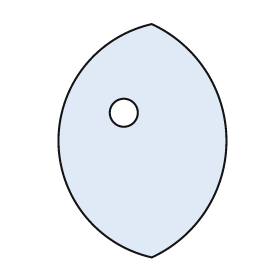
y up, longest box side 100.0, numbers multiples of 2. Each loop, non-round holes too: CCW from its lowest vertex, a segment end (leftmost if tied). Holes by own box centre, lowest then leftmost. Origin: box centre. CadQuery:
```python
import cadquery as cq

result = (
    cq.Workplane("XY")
    .moveTo(4.0, -50.0)
    .threePointArc((36.0, 0.0), (4.0, 50.0))
    .threePointArc((-36.0, 0.0), (4.0, -50.0))
    .close()
    .moveTo(-8.0, 12.0)
    .circle(6.0)
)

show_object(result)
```